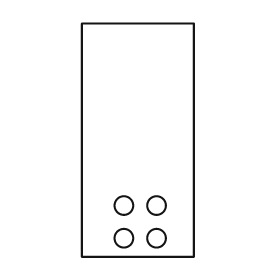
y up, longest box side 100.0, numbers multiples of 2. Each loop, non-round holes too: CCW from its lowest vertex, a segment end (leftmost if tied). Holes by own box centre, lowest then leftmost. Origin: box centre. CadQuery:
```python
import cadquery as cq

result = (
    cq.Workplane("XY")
    .moveTo(-24.0, -50.0)
    .lineTo(24.0, -50.0)
    .lineTo(24.0, 50.0)
    .lineTo(-24.0, 50.0)
    .close()
    .moveTo(-6.0, -42.0)
    .circle(4.0)
    .moveTo(8.0, -42.0)
    .circle(4.0)
    .moveTo(-6.0, -28.0)
    .circle(4.0)
    .moveTo(8.0, -28.0)
    .circle(4.0)
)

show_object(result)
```